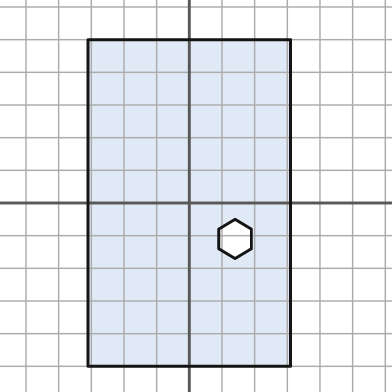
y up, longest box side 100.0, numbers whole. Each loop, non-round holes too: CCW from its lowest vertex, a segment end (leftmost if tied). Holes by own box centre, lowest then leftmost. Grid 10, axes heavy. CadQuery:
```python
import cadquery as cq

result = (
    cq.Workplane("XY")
    .moveTo(-31.0, -50.0)
    .lineTo(31.0, -50.0)
    .lineTo(31.0, 50.0)
    .lineTo(-31.0, 50.0)
    .close()
    .moveTo(14.0, -17.0)
    .lineTo(19.0, -14.0)
    .lineTo(19.0, -8.0)
    .lineTo(14.0, -5.0)
    .lineTo(9.0, -8.0)
    .lineTo(9.0, -14.0)
    .close()
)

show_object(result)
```